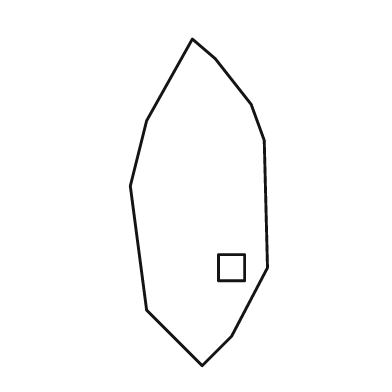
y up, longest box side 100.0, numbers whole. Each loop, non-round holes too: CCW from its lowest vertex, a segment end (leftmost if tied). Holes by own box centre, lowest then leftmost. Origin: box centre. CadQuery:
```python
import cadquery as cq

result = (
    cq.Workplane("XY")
    .moveTo(1.0, -50.0)
    .lineTo(10.0, -41.0)
    .lineTo(21.0, -20.0)
    .lineTo(20.0, 19.0)
    .lineTo(16.0, 30.0)
    .lineTo(5.0, 44.0)
    .lineTo(-2.0, 50.0)
    .lineTo(-16.0, 25.0)
    .lineTo(-21.0, 5.0)
    .lineTo(-16.0, -33.0)
    .close()
    .moveTo(6.0, -24.0)
    .lineTo(14.0, -24.0)
    .lineTo(14.0, -16.0)
    .lineTo(6.0, -16.0)
    .close()
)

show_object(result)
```